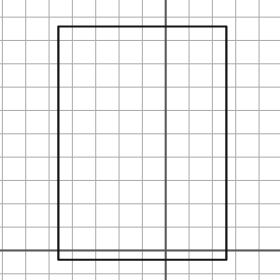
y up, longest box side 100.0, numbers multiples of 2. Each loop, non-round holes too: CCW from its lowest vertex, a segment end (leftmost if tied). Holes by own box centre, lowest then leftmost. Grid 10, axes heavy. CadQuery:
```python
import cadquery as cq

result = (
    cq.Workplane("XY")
    .moveTo(-46.0, -4.0)
    .lineTo(26.0, -4.0)
    .lineTo(26.0, 96.0)
    .lineTo(-46.0, 96.0)
    .close()
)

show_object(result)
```